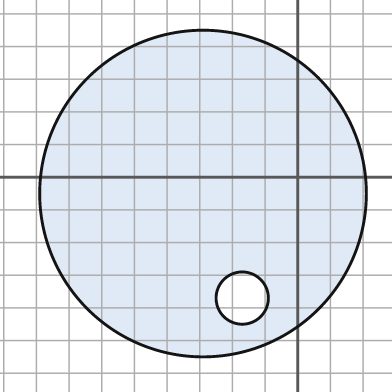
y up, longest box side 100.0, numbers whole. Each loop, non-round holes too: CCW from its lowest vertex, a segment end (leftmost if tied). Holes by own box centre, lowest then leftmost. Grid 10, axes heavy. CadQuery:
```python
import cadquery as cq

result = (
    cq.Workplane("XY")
    .moveTo(-29.0, -5.0)
    .circle(50.0)
    .moveTo(-17.0, -37.0)
    .circle(8.0)
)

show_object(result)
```